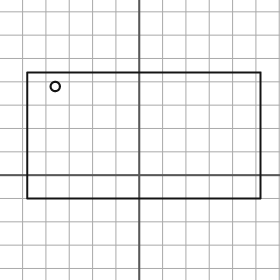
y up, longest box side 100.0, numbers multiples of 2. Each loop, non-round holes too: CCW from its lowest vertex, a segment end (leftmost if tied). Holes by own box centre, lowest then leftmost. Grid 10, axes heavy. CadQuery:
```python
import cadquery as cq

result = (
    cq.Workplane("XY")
    .moveTo(-48.0, -10.0)
    .lineTo(52.0, -10.0)
    .lineTo(52.0, 44.0)
    .lineTo(-48.0, 44.0)
    .close()
    .moveTo(-36.0, 38.0)
    .circle(2.0)
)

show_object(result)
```